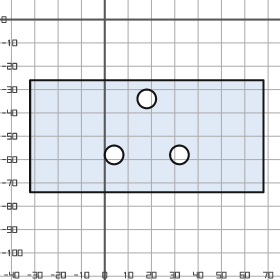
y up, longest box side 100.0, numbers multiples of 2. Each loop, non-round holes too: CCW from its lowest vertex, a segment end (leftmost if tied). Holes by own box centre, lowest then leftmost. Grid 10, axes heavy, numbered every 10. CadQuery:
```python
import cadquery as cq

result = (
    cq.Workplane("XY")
    .moveTo(-32.0, -74.0)
    .lineTo(68.0, -74.0)
    .lineTo(68.0, -26.0)
    .lineTo(-32.0, -26.0)
    .close()
    .moveTo(4.0, -58.0)
    .circle(4.0)
    .moveTo(32.0, -58.0)
    .circle(4.0)
    .moveTo(18.0, -34.0)
    .circle(4.0)
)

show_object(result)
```